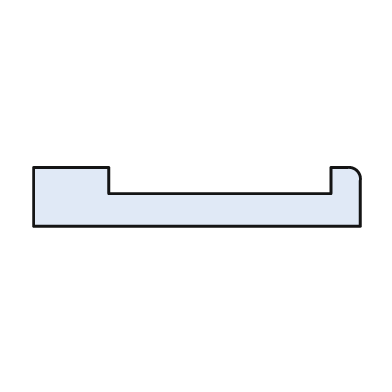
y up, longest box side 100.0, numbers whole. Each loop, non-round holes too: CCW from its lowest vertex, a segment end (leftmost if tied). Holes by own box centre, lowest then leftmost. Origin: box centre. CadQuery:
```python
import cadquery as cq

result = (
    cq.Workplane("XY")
    .moveTo(-50.0, -9.0)
    .lineTo(50.0, -9.0)
    .lineTo(50.0, 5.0)
    .threePointArc((49.0, 8.0), (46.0, 9.0))
    .lineTo(41.0, 9.0)
    .lineTo(41.0, 1.0)
    .lineTo(-27.0, 1.0)
    .lineTo(-27.0, 9.0)
    .lineTo(-50.0, 9.0)
    .close()
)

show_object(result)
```